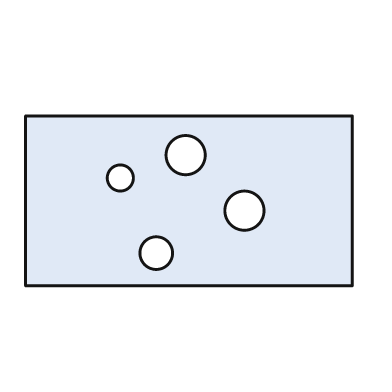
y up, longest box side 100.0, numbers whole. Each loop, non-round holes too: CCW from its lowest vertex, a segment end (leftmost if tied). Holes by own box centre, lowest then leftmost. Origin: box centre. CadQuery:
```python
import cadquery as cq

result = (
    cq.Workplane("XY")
    .moveTo(-50.0, -26.0)
    .lineTo(50.0, -26.0)
    .lineTo(50.0, 26.0)
    .lineTo(-50.0, 26.0)
    .close()
    .moveTo(-10.0, -16.0)
    .circle(5.0)
    .moveTo(17.0, -3.0)
    .circle(6.0)
    .moveTo(-21.0, 7.0)
    .circle(4.0)
    .moveTo(-1.0, 14.0)
    .circle(6.0)
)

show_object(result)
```